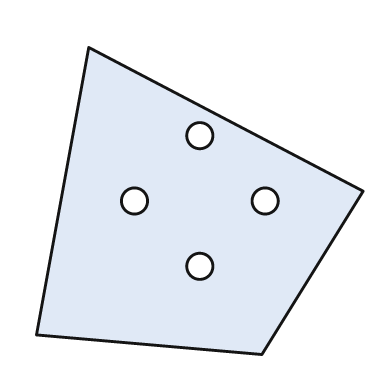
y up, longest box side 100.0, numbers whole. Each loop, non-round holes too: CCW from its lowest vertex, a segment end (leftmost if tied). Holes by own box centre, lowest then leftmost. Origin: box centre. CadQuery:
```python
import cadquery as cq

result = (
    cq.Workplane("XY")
    .moveTo(19.0, -47.0)
    .lineTo(50.0, 3.0)
    .lineTo(-34.0, 47.0)
    .lineTo(-50.0, -41.0)
    .close()
    .moveTo(0.0, -20.0)
    .circle(4.0)
    .moveTo(-20.0, 0.0)
    .circle(4.0)
    .moveTo(20.0, 0.0)
    .circle(4.0)
    .moveTo(0.0, 20.0)
    .circle(4.0)
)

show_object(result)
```